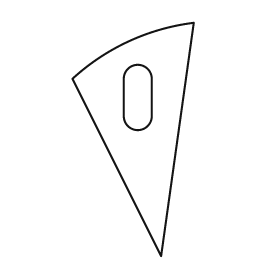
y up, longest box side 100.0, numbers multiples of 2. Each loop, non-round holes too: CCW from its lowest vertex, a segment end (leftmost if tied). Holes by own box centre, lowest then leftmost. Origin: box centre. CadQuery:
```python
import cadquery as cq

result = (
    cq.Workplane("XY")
    .moveTo(12.0, -50.0)
    .lineTo(26.0, 50.0)
    .threePointArc((-2.0, 42.0), (-26.0, 26.0))
    .close()
    .moveTo(-4.0, 10.0)
    .threePointArc((2.0, 4.0), (8.0, 10.0))
    .lineTo(8.0, 26.0)
    .threePointArc((2.0, 32.0), (-4.0, 26.0))
    .close()
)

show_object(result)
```